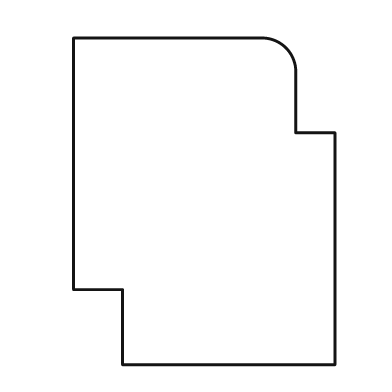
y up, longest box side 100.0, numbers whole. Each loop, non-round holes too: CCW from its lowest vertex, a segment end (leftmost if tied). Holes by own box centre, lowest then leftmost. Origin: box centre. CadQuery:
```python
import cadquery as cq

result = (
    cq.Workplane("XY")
    .moveTo(-25.0, -50.0)
    .lineTo(40.0, -50.0)
    .lineTo(40.0, 21.0)
    .lineTo(28.0, 21.0)
    .lineTo(28.0, 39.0)
    .threePointArc((25.0, 47.0), (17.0, 50.0))
    .lineTo(-40.0, 50.0)
    .lineTo(-40.0, -27.0)
    .lineTo(-25.0, -27.0)
    .close()
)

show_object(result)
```